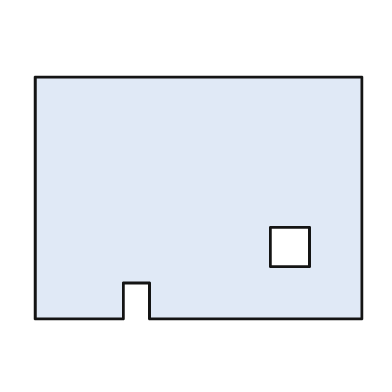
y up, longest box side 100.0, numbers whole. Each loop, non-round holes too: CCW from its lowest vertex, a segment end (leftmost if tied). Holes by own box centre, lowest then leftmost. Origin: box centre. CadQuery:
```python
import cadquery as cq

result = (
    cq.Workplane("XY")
    .moveTo(-50.0, -37.0)
    .lineTo(-23.0, -37.0)
    .lineTo(-23.0, -26.0)
    .lineTo(-15.0, -26.0)
    .lineTo(-15.0, -37.0)
    .lineTo(50.0, -37.0)
    .lineTo(50.0, 37.0)
    .lineTo(-50.0, 37.0)
    .close()
    .moveTo(22.0, -21.0)
    .lineTo(34.0, -21.0)
    .lineTo(34.0, -9.0)
    .lineTo(22.0, -9.0)
    .close()
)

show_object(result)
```